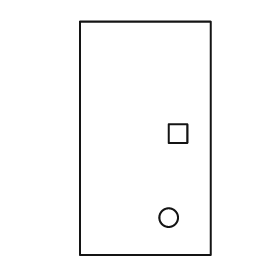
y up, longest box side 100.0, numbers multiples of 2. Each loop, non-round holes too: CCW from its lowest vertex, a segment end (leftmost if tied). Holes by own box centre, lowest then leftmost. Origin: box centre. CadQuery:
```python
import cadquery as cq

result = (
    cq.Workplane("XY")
    .moveTo(-28.0, -50.0)
    .lineTo(28.0, -50.0)
    .lineTo(28.0, 50.0)
    .lineTo(-28.0, 50.0)
    .close()
    .moveTo(10.0, -34.0)
    .circle(4.0)
    .moveTo(10.0, -2.0)
    .lineTo(18.0, -2.0)
    .lineTo(18.0, 6.0)
    .lineTo(10.0, 6.0)
    .close()
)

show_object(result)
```